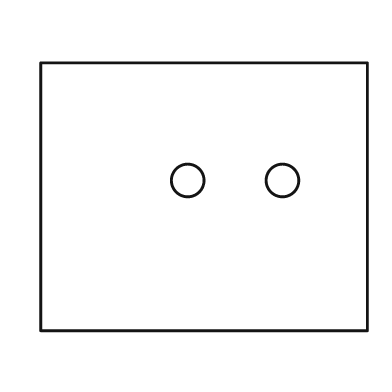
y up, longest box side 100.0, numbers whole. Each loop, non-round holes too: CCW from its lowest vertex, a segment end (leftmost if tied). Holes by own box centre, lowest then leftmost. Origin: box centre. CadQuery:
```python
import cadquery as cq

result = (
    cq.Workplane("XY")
    .moveTo(-50.0, -41.0)
    .lineTo(50.0, -41.0)
    .lineTo(50.0, 41.0)
    .lineTo(-50.0, 41.0)
    .close()
    .moveTo(-5.0, 5.0)
    .circle(5.0)
    .moveTo(24.0, 5.0)
    .circle(5.0)
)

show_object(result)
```